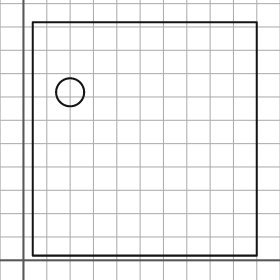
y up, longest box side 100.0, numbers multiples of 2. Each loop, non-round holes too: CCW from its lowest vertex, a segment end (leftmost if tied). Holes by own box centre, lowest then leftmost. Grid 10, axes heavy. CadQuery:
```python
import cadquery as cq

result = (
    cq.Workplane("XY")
    .moveTo(4.0, 2.0)
    .lineTo(100.0, 2.0)
    .lineTo(100.0, 102.0)
    .lineTo(4.0, 102.0)
    .close()
    .moveTo(20.0, 72.0)
    .circle(6.0)
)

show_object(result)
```